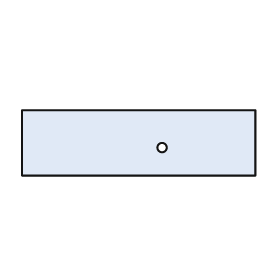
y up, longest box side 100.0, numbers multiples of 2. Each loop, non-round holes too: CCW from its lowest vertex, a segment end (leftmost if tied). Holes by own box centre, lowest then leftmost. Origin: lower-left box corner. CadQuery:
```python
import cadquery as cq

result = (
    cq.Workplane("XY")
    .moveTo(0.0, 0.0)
    .lineTo(100.0, 0.0)
    .lineTo(100.0, 28.0)
    .lineTo(0.0, 28.0)
    .close()
    .moveTo(60.0, 12.0)
    .circle(2.0)
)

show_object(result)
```